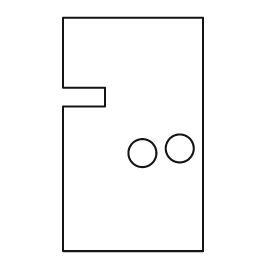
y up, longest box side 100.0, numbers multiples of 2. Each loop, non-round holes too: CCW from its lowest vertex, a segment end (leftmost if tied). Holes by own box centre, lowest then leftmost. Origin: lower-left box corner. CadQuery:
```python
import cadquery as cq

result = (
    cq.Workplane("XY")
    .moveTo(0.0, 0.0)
    .lineTo(60.0, 0.0)
    .lineTo(60.0, 100.0)
    .lineTo(0.0, 100.0)
    .lineTo(0.0, 70.0)
    .lineTo(18.0, 70.0)
    .lineTo(18.0, 62.0)
    .lineTo(0.0, 62.0)
    .close()
    .moveTo(34.0, 42.0)
    .circle(6.0)
    .moveTo(50.0, 44.0)
    .circle(6.0)
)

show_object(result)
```